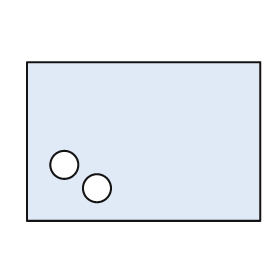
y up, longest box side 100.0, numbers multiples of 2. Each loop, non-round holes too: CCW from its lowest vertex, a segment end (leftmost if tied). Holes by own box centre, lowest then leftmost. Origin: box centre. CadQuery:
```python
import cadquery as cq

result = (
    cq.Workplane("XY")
    .moveTo(-50.0, -34.0)
    .lineTo(50.0, -34.0)
    .lineTo(50.0, 34.0)
    .lineTo(-50.0, 34.0)
    .close()
    .moveTo(-20.0, -20.0)
    .circle(6.0)
    .moveTo(-34.0, -10.0)
    .circle(6.0)
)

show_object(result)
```